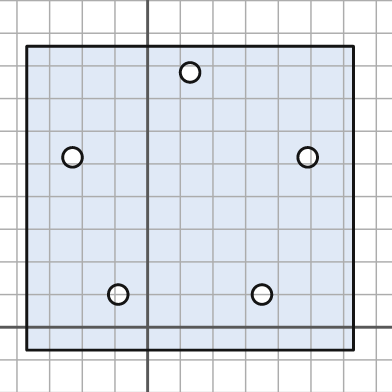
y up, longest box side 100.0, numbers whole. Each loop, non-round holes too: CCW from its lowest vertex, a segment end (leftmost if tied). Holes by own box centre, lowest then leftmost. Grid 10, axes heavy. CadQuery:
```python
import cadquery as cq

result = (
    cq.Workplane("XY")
    .moveTo(-37.0, -7.0)
    .lineTo(63.0, -7.0)
    .lineTo(63.0, 86.0)
    .lineTo(-37.0, 86.0)
    .close()
    .moveTo(-9.0, 10.0)
    .circle(3.0)
    .moveTo(35.0, 10.0)
    .circle(3.0)
    .moveTo(-23.0, 52.0)
    .circle(3.0)
    .moveTo(49.0, 52.0)
    .circle(3.0)
    .moveTo(13.0, 78.0)
    .circle(3.0)
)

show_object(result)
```